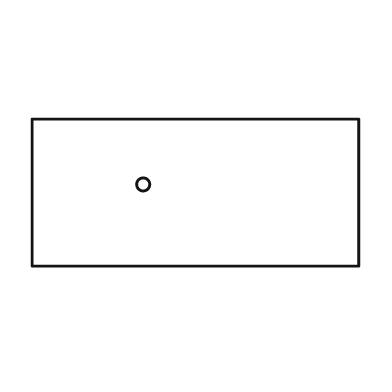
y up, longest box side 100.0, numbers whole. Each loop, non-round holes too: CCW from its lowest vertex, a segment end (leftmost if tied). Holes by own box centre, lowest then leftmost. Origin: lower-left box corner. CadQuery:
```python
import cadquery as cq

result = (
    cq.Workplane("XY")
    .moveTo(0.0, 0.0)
    .lineTo(100.0, 0.0)
    .lineTo(100.0, 45.0)
    .lineTo(0.0, 45.0)
    .close()
    .moveTo(34.0, 25.0)
    .circle(2.0)
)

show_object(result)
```